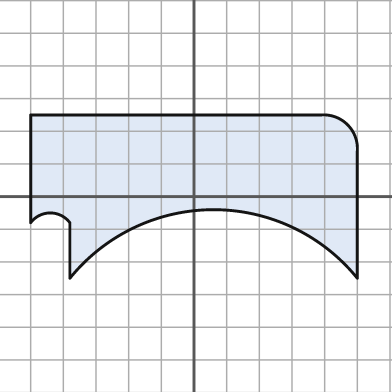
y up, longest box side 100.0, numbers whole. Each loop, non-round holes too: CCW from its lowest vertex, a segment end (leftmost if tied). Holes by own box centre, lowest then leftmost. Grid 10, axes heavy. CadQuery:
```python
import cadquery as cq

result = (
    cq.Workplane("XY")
    .moveTo(-38.0, -25.0)
    .threePointArc((6.0, -4.0), (50.0, -25.0))
    .lineTo(50.0, 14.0)
    .threePointArc((47.0, 22.0), (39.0, 25.0))
    .lineTo(-50.0, 25.0)
    .lineTo(-50.0, -8.0)
    .threePointArc((-44.0, -5.0), (-38.0, -8.0))
    .close()
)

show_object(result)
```